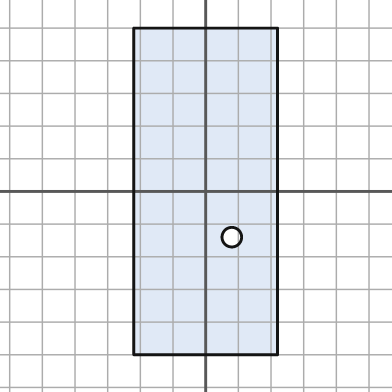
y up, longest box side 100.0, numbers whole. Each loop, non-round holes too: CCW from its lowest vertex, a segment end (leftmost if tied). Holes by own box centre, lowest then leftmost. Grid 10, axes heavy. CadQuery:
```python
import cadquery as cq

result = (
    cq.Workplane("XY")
    .moveTo(-22.0, -50.0)
    .lineTo(22.0, -50.0)
    .lineTo(22.0, 50.0)
    .lineTo(-22.0, 50.0)
    .close()
    .moveTo(8.0, -14.0)
    .circle(3.0)
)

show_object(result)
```